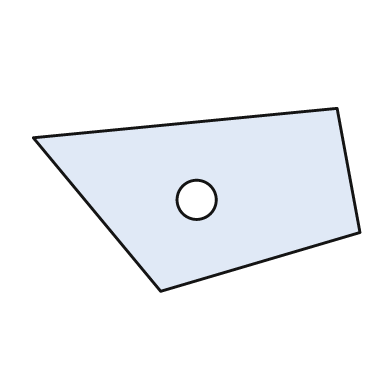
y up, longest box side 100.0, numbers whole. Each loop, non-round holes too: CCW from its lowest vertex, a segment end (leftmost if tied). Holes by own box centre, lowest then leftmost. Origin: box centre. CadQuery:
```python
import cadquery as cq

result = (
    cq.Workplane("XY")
    .moveTo(-11.0, -28.0)
    .lineTo(50.0, -10.0)
    .lineTo(43.0, 28.0)
    .lineTo(-50.0, 19.0)
    .close()
    .moveTo(0.0, 0.0)
    .circle(6.0)
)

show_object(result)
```